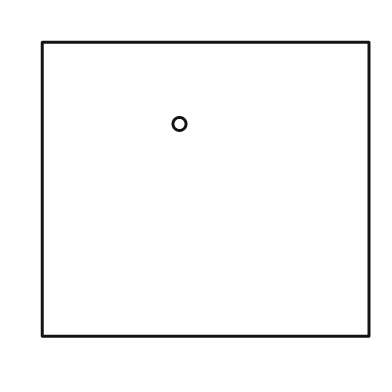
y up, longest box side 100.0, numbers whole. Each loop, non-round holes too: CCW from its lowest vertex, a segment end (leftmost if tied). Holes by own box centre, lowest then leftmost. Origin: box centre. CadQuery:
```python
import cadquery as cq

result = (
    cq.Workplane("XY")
    .moveTo(-50.0, -45.0)
    .lineTo(50.0, -45.0)
    .lineTo(50.0, 45.0)
    .lineTo(-50.0, 45.0)
    .close()
    .moveTo(-8.0, 20.0)
    .circle(2.0)
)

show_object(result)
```